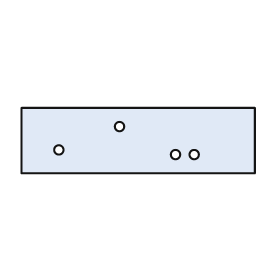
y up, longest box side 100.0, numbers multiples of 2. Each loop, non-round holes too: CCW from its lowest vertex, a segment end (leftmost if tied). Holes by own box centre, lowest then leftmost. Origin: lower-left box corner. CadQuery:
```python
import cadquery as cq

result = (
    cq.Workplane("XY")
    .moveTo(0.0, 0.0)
    .lineTo(100.0, 0.0)
    .lineTo(100.0, 28.0)
    .lineTo(0.0, 28.0)
    .close()
    .moveTo(66.0, 8.0)
    .circle(2.0)
    .moveTo(74.0, 8.0)
    .circle(2.0)
    .moveTo(16.0, 10.0)
    .circle(2.0)
    .moveTo(42.0, 20.0)
    .circle(2.0)
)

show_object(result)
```